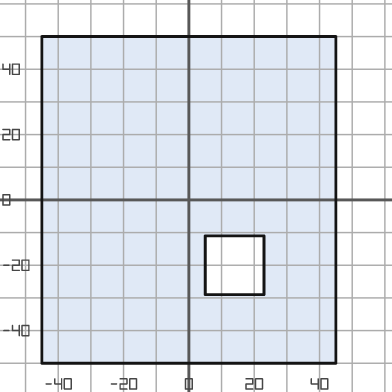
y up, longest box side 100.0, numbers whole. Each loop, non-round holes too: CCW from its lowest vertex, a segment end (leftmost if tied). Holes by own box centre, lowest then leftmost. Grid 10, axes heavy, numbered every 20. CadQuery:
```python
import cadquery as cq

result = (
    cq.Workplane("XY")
    .moveTo(-45.0, -50.0)
    .lineTo(45.0, -50.0)
    .lineTo(45.0, 50.0)
    .lineTo(-45.0, 50.0)
    .close()
    .moveTo(5.0, -29.0)
    .lineTo(23.0, -29.0)
    .lineTo(23.0, -11.0)
    .lineTo(5.0, -11.0)
    .close()
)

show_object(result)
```